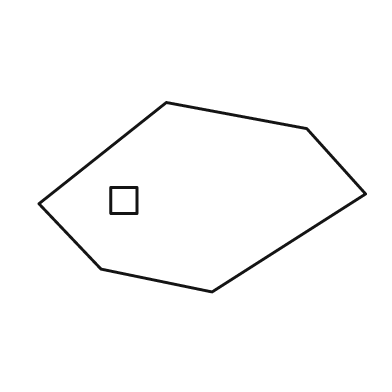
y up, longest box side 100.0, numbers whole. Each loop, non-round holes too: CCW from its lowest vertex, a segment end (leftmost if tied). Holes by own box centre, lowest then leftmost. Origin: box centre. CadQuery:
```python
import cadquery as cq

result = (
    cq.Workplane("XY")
    .moveTo(3.0, -29.0)
    .lineTo(50.0, 1.0)
    .lineTo(32.0, 21.0)
    .lineTo(-11.0, 29.0)
    .lineTo(-50.0, -2.0)
    .lineTo(-31.0, -22.0)
    .close()
    .moveTo(-28.0, -5.0)
    .lineTo(-20.0, -5.0)
    .lineTo(-20.0, 3.0)
    .lineTo(-28.0, 3.0)
    .close()
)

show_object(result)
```